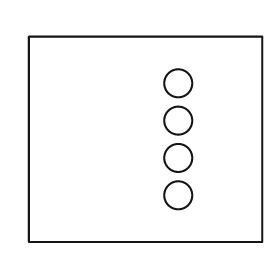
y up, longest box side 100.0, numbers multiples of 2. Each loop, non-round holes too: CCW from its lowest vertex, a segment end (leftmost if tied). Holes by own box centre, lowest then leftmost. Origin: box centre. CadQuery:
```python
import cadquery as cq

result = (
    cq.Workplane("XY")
    .moveTo(-50.0, -44.0)
    .lineTo(50.0, -44.0)
    .lineTo(50.0, 44.0)
    .lineTo(-50.0, 44.0)
    .close()
    .moveTo(14.0, -24.0)
    .circle(6.0)
    .moveTo(14.0, -8.0)
    .circle(6.0)
    .moveTo(14.0, 8.0)
    .circle(6.0)
    .moveTo(14.0, 24.0)
    .circle(6.0)
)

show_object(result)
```